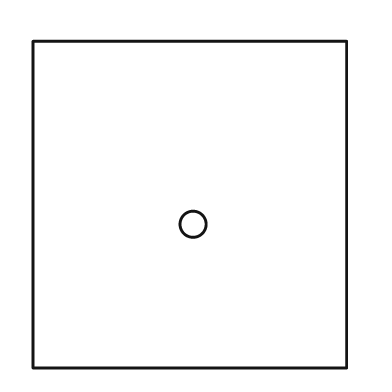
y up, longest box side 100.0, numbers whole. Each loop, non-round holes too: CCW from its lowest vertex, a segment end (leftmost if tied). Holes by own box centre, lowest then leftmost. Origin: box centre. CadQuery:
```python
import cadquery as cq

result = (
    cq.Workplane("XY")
    .moveTo(-48.0, -50.0)
    .lineTo(48.0, -50.0)
    .lineTo(48.0, 50.0)
    .lineTo(-48.0, 50.0)
    .close()
    .moveTo(1.0, -6.0)
    .circle(4.0)
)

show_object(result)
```